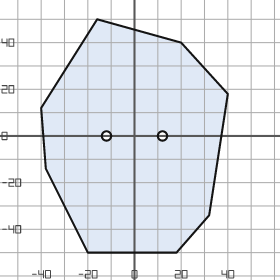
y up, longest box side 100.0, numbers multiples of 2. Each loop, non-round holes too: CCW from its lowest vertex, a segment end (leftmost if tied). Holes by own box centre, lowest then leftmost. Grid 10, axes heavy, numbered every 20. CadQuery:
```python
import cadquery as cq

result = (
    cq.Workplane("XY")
    .moveTo(-20.0, -50.0)
    .lineTo(18.0, -50.0)
    .lineTo(32.0, -34.0)
    .lineTo(40.0, 18.0)
    .lineTo(20.0, 40.0)
    .lineTo(-16.0, 50.0)
    .lineTo(-40.0, 12.0)
    .lineTo(-38.0, -14.0)
    .close()
    .moveTo(-12.0, 0.0)
    .circle(2.0)
    .moveTo(12.0, 0.0)
    .circle(2.0)
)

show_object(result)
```